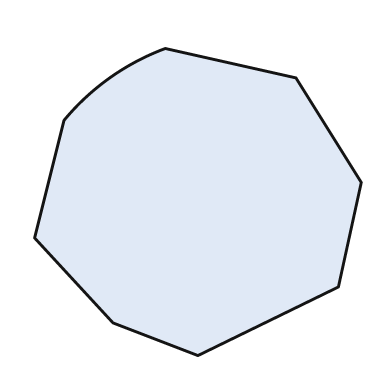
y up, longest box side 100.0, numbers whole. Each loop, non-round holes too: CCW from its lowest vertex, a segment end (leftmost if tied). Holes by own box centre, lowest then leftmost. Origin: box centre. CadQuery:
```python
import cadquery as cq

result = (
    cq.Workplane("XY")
    .moveTo(0.0, -47.0)
    .lineTo(43.0, -26.0)
    .lineTo(50.0, 6.0)
    .lineTo(30.0, 38.0)
    .lineTo(-10.0, 47.0)
    .threePointArc((-27.0, 38.0), (-41.0, 25.0))
    .lineTo(-50.0, -11.0)
    .lineTo(-26.0, -37.0)
    .close()
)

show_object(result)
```